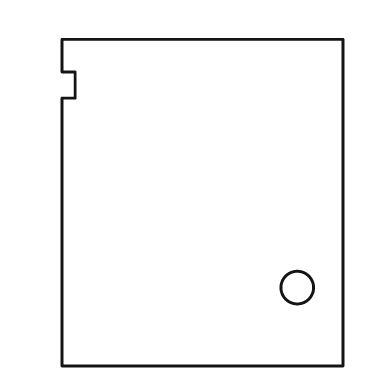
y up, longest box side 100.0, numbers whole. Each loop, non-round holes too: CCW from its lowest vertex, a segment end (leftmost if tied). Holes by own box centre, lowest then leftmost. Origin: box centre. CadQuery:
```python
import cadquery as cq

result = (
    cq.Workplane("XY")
    .moveTo(-43.0, -50.0)
    .lineTo(43.0, -50.0)
    .lineTo(43.0, 50.0)
    .lineTo(-43.0, 50.0)
    .lineTo(-43.0, 40.0)
    .lineTo(-39.0, 40.0)
    .lineTo(-39.0, 32.0)
    .lineTo(-43.0, 32.0)
    .close()
    .moveTo(29.0, -26.0)
    .circle(5.0)
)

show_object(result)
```